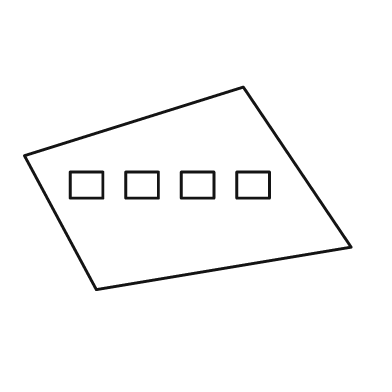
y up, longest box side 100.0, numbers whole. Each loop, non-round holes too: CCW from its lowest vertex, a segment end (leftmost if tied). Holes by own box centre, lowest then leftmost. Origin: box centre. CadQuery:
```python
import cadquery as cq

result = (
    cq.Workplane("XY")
    .moveTo(-28.0, -31.0)
    .lineTo(50.0, -18.0)
    .lineTo(17.0, 31.0)
    .lineTo(-50.0, 10.0)
    .close()
    .moveTo(-36.0, -3.0)
    .lineTo(-26.0, -3.0)
    .lineTo(-26.0, 5.0)
    .lineTo(-36.0, 5.0)
    .close()
    .moveTo(-19.0, -3.0)
    .lineTo(-9.0, -3.0)
    .lineTo(-9.0, 5.0)
    .lineTo(-19.0, 5.0)
    .close()
    .moveTo(-2.0, -3.0)
    .lineTo(8.0, -3.0)
    .lineTo(8.0, 5.0)
    .lineTo(-2.0, 5.0)
    .close()
    .moveTo(15.0, -3.0)
    .lineTo(25.0, -3.0)
    .lineTo(25.0, 5.0)
    .lineTo(15.0, 5.0)
    .close()
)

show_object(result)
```